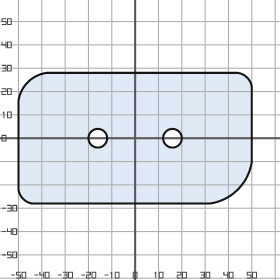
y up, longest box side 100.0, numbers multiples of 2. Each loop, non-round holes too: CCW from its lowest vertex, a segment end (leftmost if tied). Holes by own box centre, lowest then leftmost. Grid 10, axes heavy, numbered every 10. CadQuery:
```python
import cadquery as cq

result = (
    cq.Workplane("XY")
    .moveTo(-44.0, -28.0)
    .lineTo(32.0, -28.0)
    .threePointArc((44.0, -22.0), (50.0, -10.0))
    .lineTo(50.0, 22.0)
    .threePointArc((48.0, 26.0), (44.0, 28.0))
    .lineTo(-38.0, 28.0)
    .threePointArc((-46.0, 24.0), (-50.0, 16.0))
    .lineTo(-50.0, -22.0)
    .threePointArc((-48.0, -26.0), (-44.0, -28.0))
    .close()
    .moveTo(-16.0, 0.0)
    .circle(4.0)
    .moveTo(16.0, 0.0)
    .circle(4.0)
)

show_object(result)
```